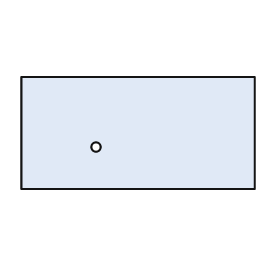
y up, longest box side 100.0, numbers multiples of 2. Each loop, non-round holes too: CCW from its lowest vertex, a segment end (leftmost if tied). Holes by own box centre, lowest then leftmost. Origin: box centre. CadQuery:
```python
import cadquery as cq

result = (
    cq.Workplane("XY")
    .moveTo(-50.0, -24.0)
    .lineTo(50.0, -24.0)
    .lineTo(50.0, 24.0)
    .lineTo(-50.0, 24.0)
    .close()
    .moveTo(-18.0, -6.0)
    .circle(2.0)
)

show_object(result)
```